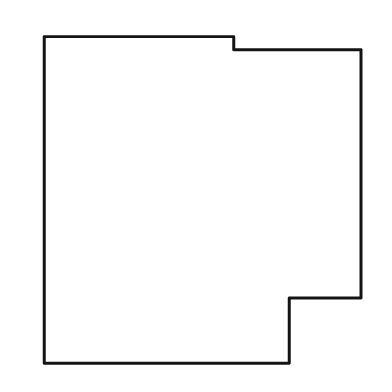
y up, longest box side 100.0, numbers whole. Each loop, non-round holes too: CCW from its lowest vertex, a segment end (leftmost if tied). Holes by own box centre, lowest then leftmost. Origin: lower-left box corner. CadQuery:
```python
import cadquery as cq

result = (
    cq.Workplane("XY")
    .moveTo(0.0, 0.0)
    .lineTo(75.0, 0.0)
    .lineTo(75.0, 20.0)
    .lineTo(97.0, 20.0)
    .lineTo(97.0, 96.0)
    .lineTo(58.0, 96.0)
    .lineTo(58.0, 100.0)
    .lineTo(0.0, 100.0)
    .close()
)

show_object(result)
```